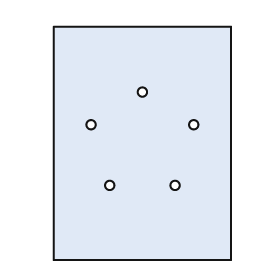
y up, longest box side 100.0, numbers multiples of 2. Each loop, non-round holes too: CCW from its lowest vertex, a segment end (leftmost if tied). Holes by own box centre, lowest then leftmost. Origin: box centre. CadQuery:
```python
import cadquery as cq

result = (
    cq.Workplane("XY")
    .moveTo(-38.0, -50.0)
    .lineTo(38.0, -50.0)
    .lineTo(38.0, 50.0)
    .lineTo(-38.0, 50.0)
    .close()
    .moveTo(-14.0, -18.0)
    .circle(2.0)
    .moveTo(14.0, -18.0)
    .circle(2.0)
    .moveTo(-22.0, 8.0)
    .circle(2.0)
    .moveTo(22.0, 8.0)
    .circle(2.0)
    .moveTo(0.0, 22.0)
    .circle(2.0)
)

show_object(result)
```